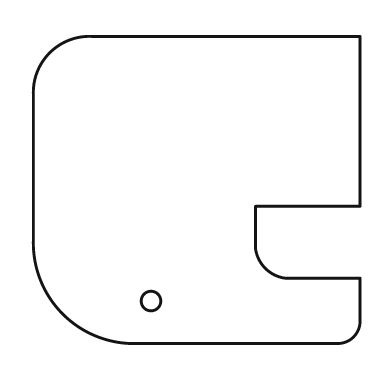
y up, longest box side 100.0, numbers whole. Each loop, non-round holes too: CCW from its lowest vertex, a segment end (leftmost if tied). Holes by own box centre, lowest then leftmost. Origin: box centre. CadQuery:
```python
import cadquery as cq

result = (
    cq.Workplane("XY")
    .moveTo(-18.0, -47.0)
    .lineTo(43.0, -47.0)
    .threePointArc((48.0, -45.0), (50.0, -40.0))
    .lineTo(50.0, -27.0)
    .lineTo(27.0, -27.0)
    .threePointArc((21.0, -24.0), (18.0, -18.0))
    .lineTo(18.0, -5.0)
    .lineTo(50.0, -5.0)
    .lineTo(50.0, 47.0)
    .lineTo(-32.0, 47.0)
    .threePointArc((-45.0, 42.0), (-50.0, 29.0))
    .lineTo(-50.0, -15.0)
    .threePointArc((-41.0, -38.0), (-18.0, -47.0))
    .close()
    .moveTo(-14.0, -34.0)
    .circle(3.0)
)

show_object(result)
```